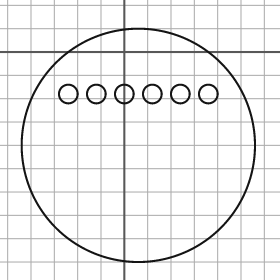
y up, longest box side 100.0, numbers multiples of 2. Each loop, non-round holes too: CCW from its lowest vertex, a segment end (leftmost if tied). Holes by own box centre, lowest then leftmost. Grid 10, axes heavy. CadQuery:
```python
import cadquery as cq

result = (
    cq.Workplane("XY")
    .moveTo(6.0, -40.0)
    .circle(50.0)
    .moveTo(-24.0, -18.0)
    .circle(4.0)
    .moveTo(-12.0, -18.0)
    .circle(4.0)
    .moveTo(0.0, -18.0)
    .circle(4.0)
    .moveTo(12.0, -18.0)
    .circle(4.0)
    .moveTo(24.0, -18.0)
    .circle(4.0)
    .moveTo(36.0, -18.0)
    .circle(4.0)
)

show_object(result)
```